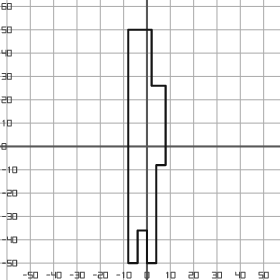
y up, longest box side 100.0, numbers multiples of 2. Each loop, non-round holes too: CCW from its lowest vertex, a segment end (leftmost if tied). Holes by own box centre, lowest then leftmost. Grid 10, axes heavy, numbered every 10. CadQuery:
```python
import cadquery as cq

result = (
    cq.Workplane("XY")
    .moveTo(-8.0, -50.0)
    .lineTo(-4.0, -50.0)
    .lineTo(-4.0, -36.0)
    .lineTo(0.0, -36.0)
    .lineTo(0.0, -50.0)
    .lineTo(4.0, -50.0)
    .lineTo(4.0, -8.0)
    .lineTo(8.0, -8.0)
    .lineTo(8.0, 26.0)
    .lineTo(2.0, 26.0)
    .lineTo(2.0, 50.0)
    .lineTo(-8.0, 50.0)
    .close()
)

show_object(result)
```